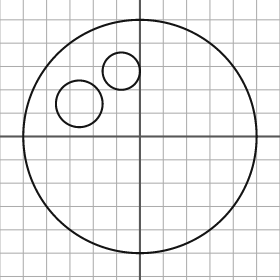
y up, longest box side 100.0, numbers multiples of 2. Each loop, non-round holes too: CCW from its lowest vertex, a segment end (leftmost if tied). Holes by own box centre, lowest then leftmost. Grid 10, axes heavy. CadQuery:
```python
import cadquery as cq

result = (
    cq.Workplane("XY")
    .moveTo(0.0, 0.0)
    .circle(50.0)
    .moveTo(-26.0, 14.0)
    .circle(10.0)
    .moveTo(-8.0, 28.0)
    .circle(8.0)
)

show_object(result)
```